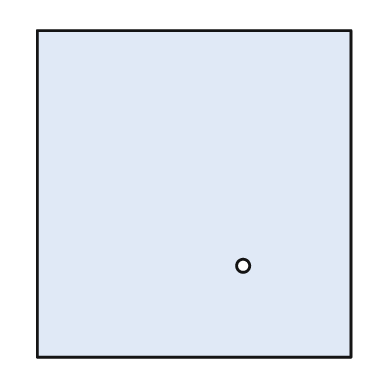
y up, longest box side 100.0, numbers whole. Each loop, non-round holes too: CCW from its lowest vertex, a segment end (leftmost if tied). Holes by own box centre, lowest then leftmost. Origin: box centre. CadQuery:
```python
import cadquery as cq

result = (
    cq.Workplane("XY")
    .moveTo(-48.0, -50.0)
    .lineTo(48.0, -50.0)
    .lineTo(48.0, 50.0)
    .lineTo(-48.0, 50.0)
    .close()
    .moveTo(15.0, -22.0)
    .circle(2.0)
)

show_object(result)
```